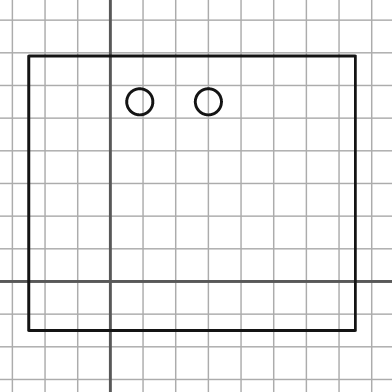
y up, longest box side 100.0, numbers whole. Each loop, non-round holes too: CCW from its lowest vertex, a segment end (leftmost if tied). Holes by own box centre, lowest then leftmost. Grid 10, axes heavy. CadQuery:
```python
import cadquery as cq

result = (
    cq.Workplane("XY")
    .moveTo(-25.0, -15.0)
    .lineTo(75.0, -15.0)
    .lineTo(75.0, 69.0)
    .lineTo(-25.0, 69.0)
    .close()
    .moveTo(9.0, 55.0)
    .circle(4.0)
    .moveTo(30.0, 55.0)
    .circle(4.0)
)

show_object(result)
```